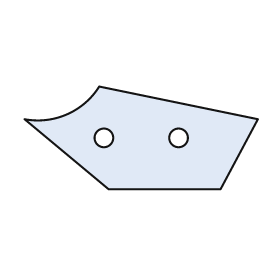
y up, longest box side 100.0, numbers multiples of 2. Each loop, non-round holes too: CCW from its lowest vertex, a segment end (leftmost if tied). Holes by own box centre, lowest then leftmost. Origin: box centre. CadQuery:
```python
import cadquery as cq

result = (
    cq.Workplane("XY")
    .moveTo(-14.0, -22.0)
    .lineTo(34.0, -22.0)
    .lineTo(50.0, 8.0)
    .lineTo(-18.0, 22.0)
    .threePointArc((-32.0, 10.0), (-50.0, 8.0))
    .close()
    .moveTo(-16.0, 0.0)
    .circle(4.0)
    .moveTo(16.0, 0.0)
    .circle(4.0)
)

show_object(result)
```